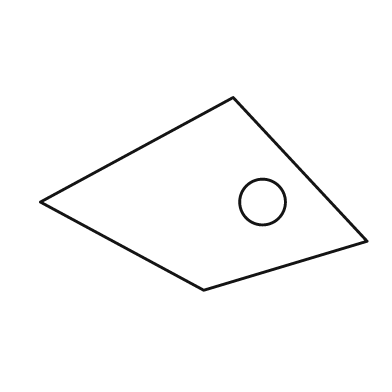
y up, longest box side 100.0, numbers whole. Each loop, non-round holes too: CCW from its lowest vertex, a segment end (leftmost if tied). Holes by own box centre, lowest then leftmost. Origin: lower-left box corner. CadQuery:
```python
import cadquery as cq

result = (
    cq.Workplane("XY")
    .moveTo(50.0, 0.0)
    .lineTo(100.0, 15.0)
    .lineTo(59.0, 59.0)
    .lineTo(0.0, 27.0)
    .close()
    .moveTo(68.0, 27.0)
    .circle(7.0)
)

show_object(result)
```